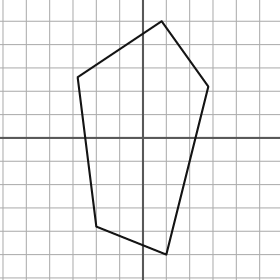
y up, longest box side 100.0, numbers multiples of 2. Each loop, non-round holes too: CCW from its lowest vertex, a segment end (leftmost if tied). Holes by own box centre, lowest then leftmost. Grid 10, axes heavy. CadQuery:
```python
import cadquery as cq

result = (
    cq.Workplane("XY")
    .moveTo(10.0, -50.0)
    .lineTo(28.0, 22.0)
    .lineTo(8.0, 50.0)
    .lineTo(-28.0, 26.0)
    .lineTo(-20.0, -38.0)
    .close()
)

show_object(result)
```